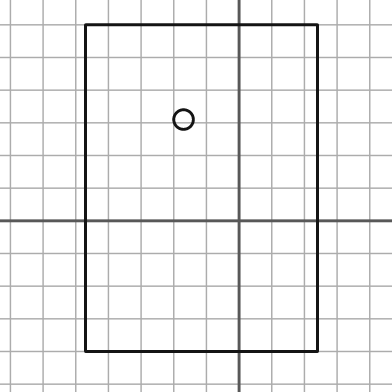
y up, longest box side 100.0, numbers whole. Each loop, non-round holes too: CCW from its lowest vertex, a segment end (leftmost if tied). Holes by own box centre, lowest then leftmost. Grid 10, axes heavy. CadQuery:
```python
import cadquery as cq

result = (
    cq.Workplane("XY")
    .moveTo(-47.0, -40.0)
    .lineTo(24.0, -40.0)
    .lineTo(24.0, 60.0)
    .lineTo(-47.0, 60.0)
    .close()
    .moveTo(-17.0, 31.0)
    .circle(3.0)
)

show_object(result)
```